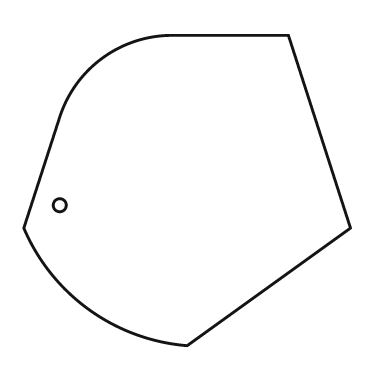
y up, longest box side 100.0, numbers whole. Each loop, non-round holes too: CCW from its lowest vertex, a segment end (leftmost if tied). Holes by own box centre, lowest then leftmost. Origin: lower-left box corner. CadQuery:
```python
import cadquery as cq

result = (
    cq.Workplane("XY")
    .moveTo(50.0, 0.0)
    .lineTo(100.0, 36.0)
    .lineTo(81.0, 95.0)
    .lineTo(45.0, 95.0)
    .threePointArc((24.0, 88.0), (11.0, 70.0))
    .lineTo(0.0, 36.0)
    .threePointArc((20.0, 11.0), (50.0, 0.0))
    .close()
    .moveTo(11.0, 43.0)
    .circle(2.0)
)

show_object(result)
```